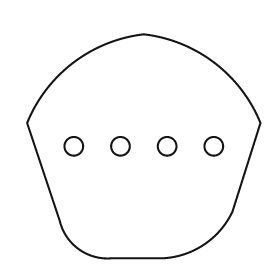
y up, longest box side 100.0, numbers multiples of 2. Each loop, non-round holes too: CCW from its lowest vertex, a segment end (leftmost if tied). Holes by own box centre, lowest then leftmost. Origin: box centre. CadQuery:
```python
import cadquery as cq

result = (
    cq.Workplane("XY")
    .moveTo(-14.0, -48.0)
    .lineTo(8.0, -48.0)
    .threePointArc((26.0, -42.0), (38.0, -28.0))
    .lineTo(50.0, 10.0)
    .threePointArc((30.0, 36.0), (0.0, 48.0))
    .threePointArc((-30.0, 36.0), (-50.0, 10.0))
    .lineTo(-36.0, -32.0)
    .threePointArc((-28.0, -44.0), (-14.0, -48.0))
    .close()
    .moveTo(-30.0, 0.0)
    .circle(4.0)
    .moveTo(-10.0, 0.0)
    .circle(4.0)
    .moveTo(10.0, 0.0)
    .circle(4.0)
    .moveTo(30.0, 0.0)
    .circle(4.0)
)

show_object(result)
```